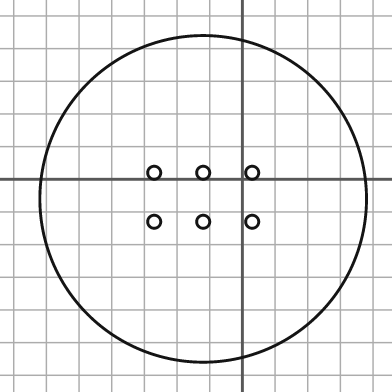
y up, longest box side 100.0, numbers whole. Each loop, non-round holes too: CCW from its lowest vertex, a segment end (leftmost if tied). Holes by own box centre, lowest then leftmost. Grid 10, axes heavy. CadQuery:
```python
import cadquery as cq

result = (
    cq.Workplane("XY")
    .moveTo(-12.0, -6.0)
    .circle(50.0)
    .moveTo(-27.0, -13.0)
    .circle(2.0)
    .moveTo(-12.0, -13.0)
    .circle(2.0)
    .moveTo(3.0, -13.0)
    .circle(2.0)
    .moveTo(-27.0, 2.0)
    .circle(2.0)
    .moveTo(-12.0, 2.0)
    .circle(2.0)
    .moveTo(3.0, 2.0)
    .circle(2.0)
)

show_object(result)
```